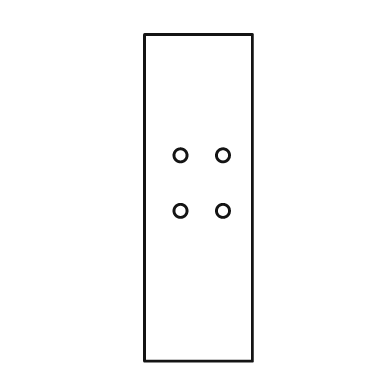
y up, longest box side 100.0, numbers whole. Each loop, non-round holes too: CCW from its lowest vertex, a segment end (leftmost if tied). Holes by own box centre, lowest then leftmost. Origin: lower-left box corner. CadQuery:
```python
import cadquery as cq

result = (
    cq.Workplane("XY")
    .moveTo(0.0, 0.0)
    .lineTo(33.0, 0.0)
    .lineTo(33.0, 100.0)
    .lineTo(0.0, 100.0)
    .close()
    .moveTo(11.0, 46.0)
    .circle(2.0)
    .moveTo(24.0, 46.0)
    .circle(2.0)
    .moveTo(11.0, 63.0)
    .circle(2.0)
    .moveTo(24.0, 63.0)
    .circle(2.0)
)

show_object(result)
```